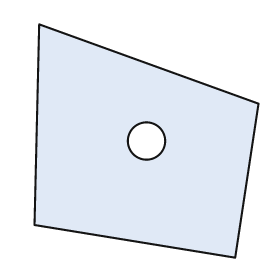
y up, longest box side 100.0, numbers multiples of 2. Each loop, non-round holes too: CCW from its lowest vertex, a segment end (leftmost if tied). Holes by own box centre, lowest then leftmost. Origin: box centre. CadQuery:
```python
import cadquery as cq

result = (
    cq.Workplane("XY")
    .moveTo(38.0, -50.0)
    .lineTo(48.0, 16.0)
    .lineTo(-46.0, 50.0)
    .lineTo(-48.0, -36.0)
    .close()
    .moveTo(0.0, 0.0)
    .circle(8.0)
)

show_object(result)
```